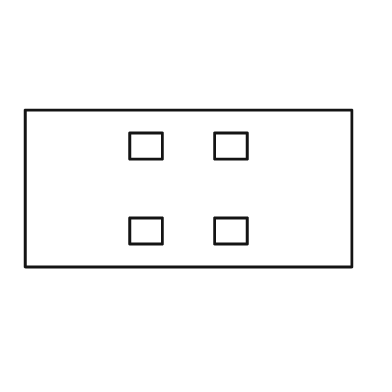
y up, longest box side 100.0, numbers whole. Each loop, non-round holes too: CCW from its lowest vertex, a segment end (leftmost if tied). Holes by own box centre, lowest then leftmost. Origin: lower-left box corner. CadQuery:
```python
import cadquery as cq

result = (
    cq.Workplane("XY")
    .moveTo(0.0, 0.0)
    .lineTo(100.0, 0.0)
    .lineTo(100.0, 48.0)
    .lineTo(0.0, 48.0)
    .close()
    .moveTo(32.0, 7.0)
    .lineTo(42.0, 7.0)
    .lineTo(42.0, 15.0)
    .lineTo(32.0, 15.0)
    .close()
    .moveTo(58.0, 7.0)
    .lineTo(68.0, 7.0)
    .lineTo(68.0, 15.0)
    .lineTo(58.0, 15.0)
    .close()
    .moveTo(32.0, 33.0)
    .lineTo(42.0, 33.0)
    .lineTo(42.0, 41.0)
    .lineTo(32.0, 41.0)
    .close()
    .moveTo(58.0, 33.0)
    .lineTo(68.0, 33.0)
    .lineTo(68.0, 41.0)
    .lineTo(58.0, 41.0)
    .close()
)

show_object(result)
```